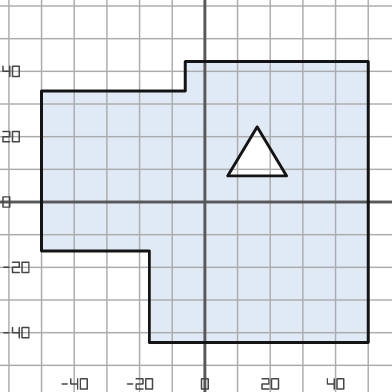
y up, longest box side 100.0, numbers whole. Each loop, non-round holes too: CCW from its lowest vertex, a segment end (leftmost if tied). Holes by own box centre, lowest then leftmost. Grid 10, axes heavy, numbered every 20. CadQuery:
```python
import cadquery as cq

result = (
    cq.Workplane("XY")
    .moveTo(-17.0, -43.0)
    .lineTo(50.0, -43.0)
    .lineTo(50.0, 43.0)
    .lineTo(-6.0, 43.0)
    .lineTo(-6.0, 34.0)
    .lineTo(-50.0, 34.0)
    .lineTo(-50.0, -15.0)
    .lineTo(-17.0, -15.0)
    .close()
    .moveTo(7.0, 8.0)
    .lineTo(25.0, 8.0)
    .lineTo(16.0, 23.0)
    .close()
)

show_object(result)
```